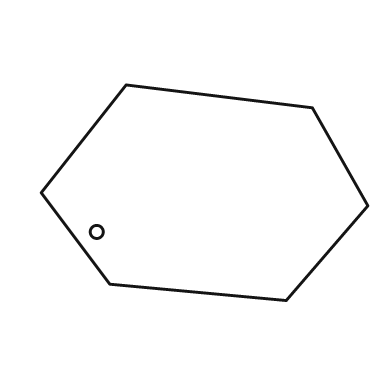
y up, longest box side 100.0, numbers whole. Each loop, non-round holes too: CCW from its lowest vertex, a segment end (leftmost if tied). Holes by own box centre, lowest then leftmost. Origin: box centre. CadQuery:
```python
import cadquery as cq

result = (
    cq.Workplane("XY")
    .moveTo(25.0, -33.0)
    .lineTo(50.0, -4.0)
    .lineTo(33.0, 26.0)
    .lineTo(-24.0, 33.0)
    .lineTo(-50.0, 0.0)
    .lineTo(-29.0, -28.0)
    .close()
    .moveTo(-33.0, -12.0)
    .circle(2.0)
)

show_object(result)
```